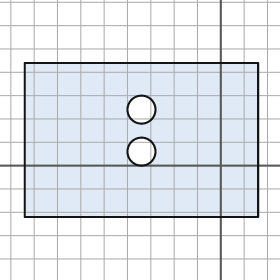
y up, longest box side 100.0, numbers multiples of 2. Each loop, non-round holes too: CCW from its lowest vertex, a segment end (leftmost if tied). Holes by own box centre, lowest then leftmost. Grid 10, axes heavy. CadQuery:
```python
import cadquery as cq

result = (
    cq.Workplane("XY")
    .moveTo(-84.0, -22.0)
    .lineTo(16.0, -22.0)
    .lineTo(16.0, 44.0)
    .lineTo(-84.0, 44.0)
    .close()
    .moveTo(-34.0, 6.0)
    .circle(6.0)
    .moveTo(-34.0, 24.0)
    .circle(6.0)
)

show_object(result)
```